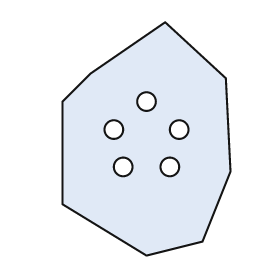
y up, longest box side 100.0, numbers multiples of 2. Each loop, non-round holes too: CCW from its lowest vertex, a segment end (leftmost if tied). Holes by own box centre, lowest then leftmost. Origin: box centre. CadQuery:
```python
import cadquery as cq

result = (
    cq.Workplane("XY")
    .moveTo(0.0, -50.0)
    .lineTo(24.0, -44.0)
    .lineTo(36.0, -14.0)
    .lineTo(34.0, 26.0)
    .lineTo(8.0, 50.0)
    .lineTo(-24.0, 28.0)
    .lineTo(-36.0, 16.0)
    .lineTo(-36.0, -28.0)
    .close()
    .moveTo(-10.0, -12.0)
    .circle(4.0)
    .moveTo(10.0, -12.0)
    .circle(4.0)
    .moveTo(-14.0, 4.0)
    .circle(4.0)
    .moveTo(14.0, 4.0)
    .circle(4.0)
    .moveTo(0.0, 16.0)
    .circle(4.0)
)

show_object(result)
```